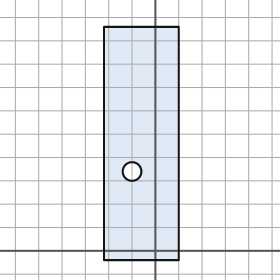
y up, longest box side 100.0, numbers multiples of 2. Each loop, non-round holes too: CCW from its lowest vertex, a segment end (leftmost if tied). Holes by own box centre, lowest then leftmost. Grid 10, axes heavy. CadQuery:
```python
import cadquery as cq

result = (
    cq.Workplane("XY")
    .moveTo(-22.0, -4.0)
    .lineTo(10.0, -4.0)
    .lineTo(10.0, 96.0)
    .lineTo(-22.0, 96.0)
    .close()
    .moveTo(-10.0, 34.0)
    .circle(4.0)
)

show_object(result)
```